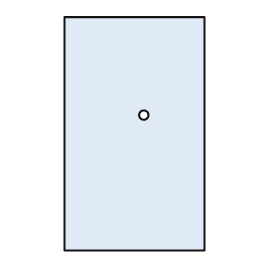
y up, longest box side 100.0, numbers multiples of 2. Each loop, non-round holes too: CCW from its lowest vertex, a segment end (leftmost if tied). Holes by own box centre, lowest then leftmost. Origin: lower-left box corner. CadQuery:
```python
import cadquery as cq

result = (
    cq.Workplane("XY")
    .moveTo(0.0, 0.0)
    .lineTo(60.0, 0.0)
    .lineTo(60.0, 100.0)
    .lineTo(0.0, 100.0)
    .close()
    .moveTo(34.0, 58.0)
    .circle(2.0)
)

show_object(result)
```